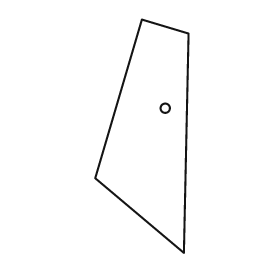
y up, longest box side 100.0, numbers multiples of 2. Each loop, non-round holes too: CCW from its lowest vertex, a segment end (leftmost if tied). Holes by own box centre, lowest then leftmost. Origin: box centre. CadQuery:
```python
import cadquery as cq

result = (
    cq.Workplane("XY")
    .moveTo(18.0, -50.0)
    .lineTo(20.0, 44.0)
    .lineTo(0.0, 50.0)
    .lineTo(-20.0, -18.0)
    .close()
    .moveTo(10.0, 12.0)
    .circle(2.0)
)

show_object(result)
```